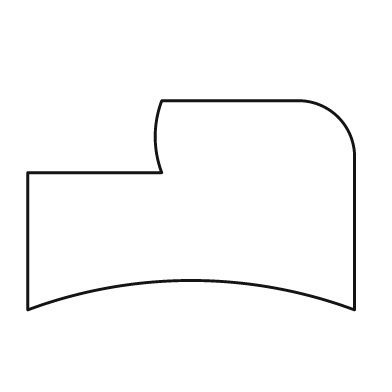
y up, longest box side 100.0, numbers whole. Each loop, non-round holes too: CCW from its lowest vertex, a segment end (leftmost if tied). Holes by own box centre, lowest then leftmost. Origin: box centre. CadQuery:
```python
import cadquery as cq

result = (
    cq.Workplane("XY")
    .moveTo(-50.0, -32.0)
    .threePointArc((0.0, -23.0), (50.0, -32.0))
    .lineTo(50.0, 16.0)
    .threePointArc((45.0, 27.0), (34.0, 32.0))
    .lineTo(-9.0, 32.0)
    .threePointArc((-11.0, 21.0), (-9.0, 10.0))
    .lineTo(-50.0, 10.0)
    .close()
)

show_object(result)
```